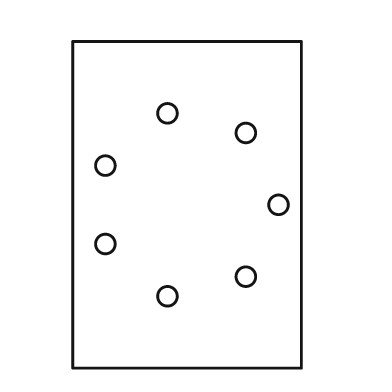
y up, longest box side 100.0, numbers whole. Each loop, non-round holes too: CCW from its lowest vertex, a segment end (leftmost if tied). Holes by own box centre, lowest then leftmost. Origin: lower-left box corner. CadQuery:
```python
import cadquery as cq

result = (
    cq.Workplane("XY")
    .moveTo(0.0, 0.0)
    .lineTo(70.0, 0.0)
    .lineTo(70.0, 100.0)
    .lineTo(0.0, 100.0)
    .close()
    .moveTo(29.0, 22.0)
    .circle(3.0)
    .moveTo(53.0, 28.0)
    .circle(3.0)
    .moveTo(10.0, 38.0)
    .circle(3.0)
    .moveTo(63.0, 50.0)
    .circle(3.0)
    .moveTo(10.0, 62.0)
    .circle(3.0)
    .moveTo(53.0, 72.0)
    .circle(3.0)
    .moveTo(29.0, 78.0)
    .circle(3.0)
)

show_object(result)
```